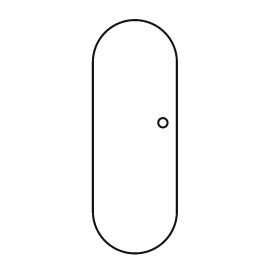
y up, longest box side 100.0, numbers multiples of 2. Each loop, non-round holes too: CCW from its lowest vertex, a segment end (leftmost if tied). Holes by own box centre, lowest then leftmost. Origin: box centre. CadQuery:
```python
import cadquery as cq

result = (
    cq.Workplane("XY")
    .moveTo(-18.0, -32.0)
    .threePointArc((0.0, -50.0), (18.0, -32.0))
    .lineTo(18.0, 32.0)
    .threePointArc((0.0, 50.0), (-18.0, 32.0))
    .close()
    .moveTo(12.0, 6.0)
    .circle(2.0)
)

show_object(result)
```